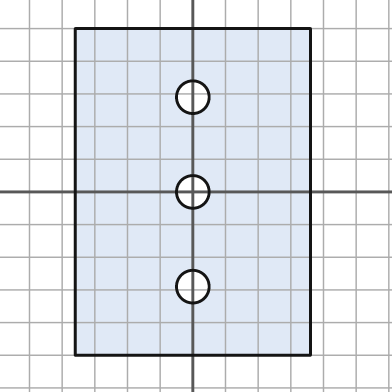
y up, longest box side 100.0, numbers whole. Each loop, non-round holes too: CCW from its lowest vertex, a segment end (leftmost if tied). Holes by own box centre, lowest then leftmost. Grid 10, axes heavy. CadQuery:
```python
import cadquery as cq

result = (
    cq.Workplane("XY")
    .moveTo(-36.0, -50.0)
    .lineTo(36.0, -50.0)
    .lineTo(36.0, 50.0)
    .lineTo(-36.0, 50.0)
    .close()
    .moveTo(0.0, -29.0)
    .circle(5.0)
    .moveTo(0.0, 0.0)
    .circle(5.0)
    .moveTo(0.0, 29.0)
    .circle(5.0)
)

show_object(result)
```